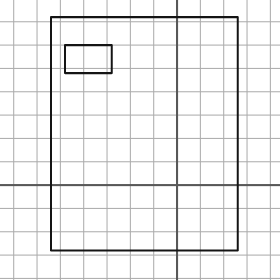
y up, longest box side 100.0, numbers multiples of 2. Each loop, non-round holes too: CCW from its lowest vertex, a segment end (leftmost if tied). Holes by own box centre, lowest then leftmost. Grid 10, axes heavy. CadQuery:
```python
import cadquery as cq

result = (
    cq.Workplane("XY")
    .moveTo(-54.0, -28.0)
    .lineTo(26.0, -28.0)
    .lineTo(26.0, 72.0)
    .lineTo(-54.0, 72.0)
    .close()
    .moveTo(-48.0, 48.0)
    .lineTo(-28.0, 48.0)
    .lineTo(-28.0, 60.0)
    .lineTo(-48.0, 60.0)
    .close()
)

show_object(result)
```